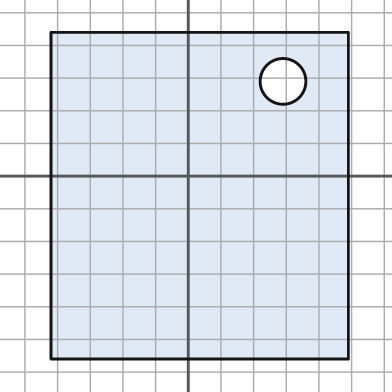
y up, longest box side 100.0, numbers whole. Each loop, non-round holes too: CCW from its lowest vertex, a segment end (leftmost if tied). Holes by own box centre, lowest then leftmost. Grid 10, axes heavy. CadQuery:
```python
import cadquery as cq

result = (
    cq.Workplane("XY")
    .moveTo(-42.0, -56.0)
    .lineTo(49.0, -56.0)
    .lineTo(49.0, 44.0)
    .lineTo(-42.0, 44.0)
    .close()
    .moveTo(29.0, 29.0)
    .circle(7.0)
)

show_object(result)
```